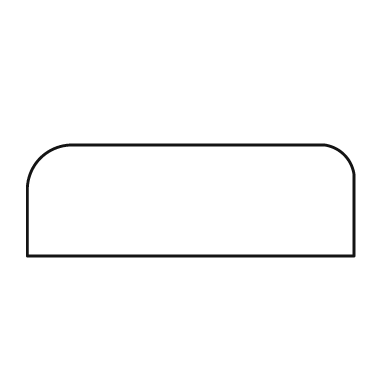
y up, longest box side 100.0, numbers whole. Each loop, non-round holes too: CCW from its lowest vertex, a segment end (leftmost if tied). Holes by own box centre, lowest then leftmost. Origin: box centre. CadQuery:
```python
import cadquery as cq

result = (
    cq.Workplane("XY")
    .moveTo(-50.0, -17.0)
    .lineTo(50.0, -17.0)
    .lineTo(50.0, 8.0)
    .threePointArc((47.0, 14.0), (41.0, 17.0))
    .lineTo(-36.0, 17.0)
    .threePointArc((-46.0, 13.0), (-50.0, 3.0))
    .close()
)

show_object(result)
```